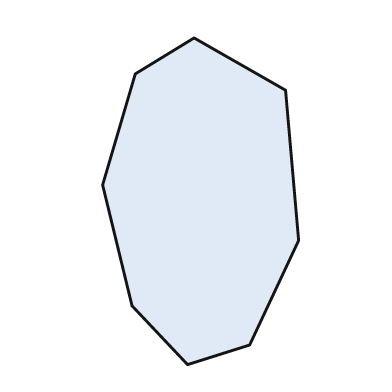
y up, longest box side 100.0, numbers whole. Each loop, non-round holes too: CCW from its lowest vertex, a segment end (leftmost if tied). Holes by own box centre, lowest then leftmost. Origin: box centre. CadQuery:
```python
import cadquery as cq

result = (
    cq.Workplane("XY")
    .moveTo(-4.0, -50.0)
    .lineTo(15.0, -44.0)
    .lineTo(30.0, -12.0)
    .lineTo(26.0, 34.0)
    .lineTo(-2.0, 50.0)
    .lineTo(-20.0, 39.0)
    .lineTo(-30.0, 5.0)
    .lineTo(-21.0, -32.0)
    .close()
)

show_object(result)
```